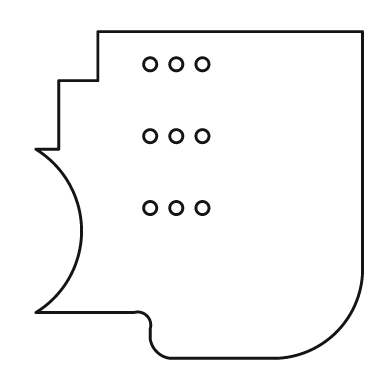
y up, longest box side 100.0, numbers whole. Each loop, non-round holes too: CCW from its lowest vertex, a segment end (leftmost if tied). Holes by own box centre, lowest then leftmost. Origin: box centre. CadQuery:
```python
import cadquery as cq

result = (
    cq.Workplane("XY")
    .moveTo(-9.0, -50.0)
    .lineTo(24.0, -50.0)
    .threePointArc((42.0, -42.0), (50.0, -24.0))
    .lineTo(50.0, 50.0)
    .lineTo(-31.0, 50.0)
    .lineTo(-31.0, 35.0)
    .lineTo(-43.0, 35.0)
    .lineTo(-43.0, 14.0)
    .lineTo(-50.0, 14.0)
    .threePointArc((-36.0, -11.0), (-50.0, -36.0))
    .lineTo(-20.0, -36.0)
    .threePointArc((-16.0, -37.0), (-15.0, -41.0))
    .lineTo(-15.0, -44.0)
    .threePointArc((-13.0, -48.0), (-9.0, -50.0))
    .close()
    .moveTo(-15.0, -4.0)
    .circle(2.0)
    .moveTo(-7.0, -4.0)
    .circle(2.0)
    .moveTo(1.0, -4.0)
    .circle(2.0)
    .moveTo(-15.0, 18.0)
    .circle(2.0)
    .moveTo(-7.0, 18.0)
    .circle(2.0)
    .moveTo(1.0, 18.0)
    .circle(2.0)
    .moveTo(-15.0, 40.0)
    .circle(2.0)
    .moveTo(-7.0, 40.0)
    .circle(2.0)
    .moveTo(1.0, 40.0)
    .circle(2.0)
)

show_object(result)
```